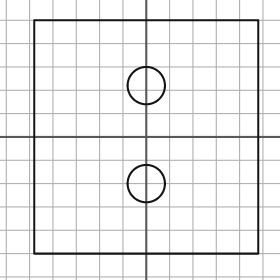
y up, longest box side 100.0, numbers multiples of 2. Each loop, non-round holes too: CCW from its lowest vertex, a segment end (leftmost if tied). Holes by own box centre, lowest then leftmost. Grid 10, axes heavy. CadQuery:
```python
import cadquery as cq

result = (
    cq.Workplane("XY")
    .moveTo(-48.0, -50.0)
    .lineTo(48.0, -50.0)
    .lineTo(48.0, 50.0)
    .lineTo(-48.0, 50.0)
    .close()
    .moveTo(0.0, -20.0)
    .circle(8.0)
    .moveTo(0.0, 22.0)
    .circle(8.0)
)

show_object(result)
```